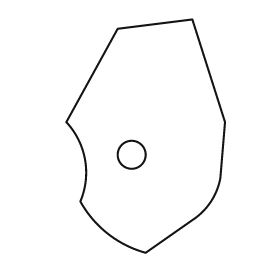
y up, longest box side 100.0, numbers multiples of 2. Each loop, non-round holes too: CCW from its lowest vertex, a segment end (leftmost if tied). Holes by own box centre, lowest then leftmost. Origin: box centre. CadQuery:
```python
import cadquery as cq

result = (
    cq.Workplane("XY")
    .moveTo(0.0, -50.0)
    .lineTo(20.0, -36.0)
    .threePointArc((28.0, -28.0), (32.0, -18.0))
    .lineTo(34.0, 6.0)
    .lineTo(20.0, 50.0)
    .lineTo(-12.0, 46.0)
    .lineTo(-34.0, 6.0)
    .threePointArc((-26.0, -10.0), (-28.0, -28.0))
    .threePointArc((-16.0, -42.0), (0.0, -50.0))
    .close()
    .moveTo(-6.0, -8.0)
    .circle(6.0)
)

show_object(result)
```